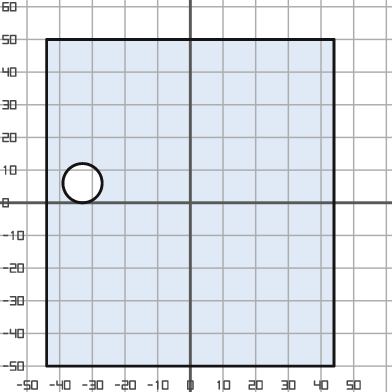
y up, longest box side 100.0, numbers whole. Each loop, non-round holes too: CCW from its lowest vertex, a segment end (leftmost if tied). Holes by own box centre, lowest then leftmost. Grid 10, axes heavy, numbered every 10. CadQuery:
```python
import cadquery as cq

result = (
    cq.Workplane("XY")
    .moveTo(-44.0, -50.0)
    .lineTo(44.0, -50.0)
    .lineTo(44.0, 50.0)
    .lineTo(-44.0, 50.0)
    .close()
    .moveTo(-33.0, 6.0)
    .circle(6.0)
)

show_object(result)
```